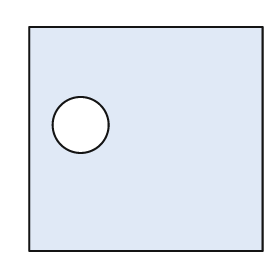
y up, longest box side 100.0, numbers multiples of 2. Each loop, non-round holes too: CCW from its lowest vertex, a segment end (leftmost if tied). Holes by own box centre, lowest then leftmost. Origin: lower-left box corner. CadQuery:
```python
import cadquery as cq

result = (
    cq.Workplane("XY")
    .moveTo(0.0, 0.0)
    .lineTo(100.0, 0.0)
    .lineTo(100.0, 96.0)
    .lineTo(0.0, 96.0)
    .close()
    .moveTo(22.0, 54.0)
    .circle(12.0)
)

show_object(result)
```